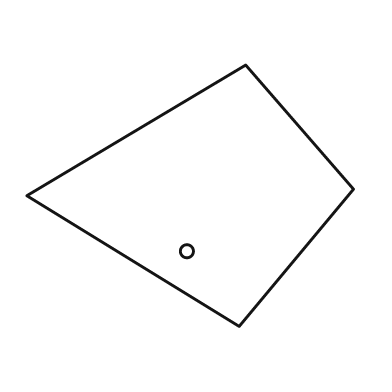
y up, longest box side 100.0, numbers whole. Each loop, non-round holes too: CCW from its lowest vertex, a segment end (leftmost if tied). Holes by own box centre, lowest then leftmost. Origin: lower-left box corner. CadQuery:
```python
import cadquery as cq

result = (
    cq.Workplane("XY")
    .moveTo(65.0, 0.0)
    .lineTo(100.0, 42.0)
    .lineTo(67.0, 80.0)
    .lineTo(0.0, 40.0)
    .close()
    .moveTo(49.0, 23.0)
    .circle(2.0)
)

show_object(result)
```